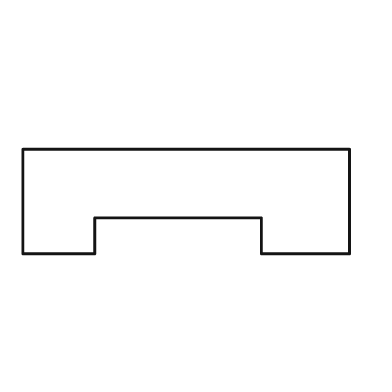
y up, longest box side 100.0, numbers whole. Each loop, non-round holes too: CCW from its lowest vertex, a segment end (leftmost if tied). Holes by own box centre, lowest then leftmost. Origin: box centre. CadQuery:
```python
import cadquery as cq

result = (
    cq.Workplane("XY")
    .moveTo(-50.0, -16.0)
    .lineTo(-28.0, -16.0)
    .lineTo(-28.0, -5.0)
    .lineTo(23.0, -5.0)
    .lineTo(23.0, -16.0)
    .lineTo(50.0, -16.0)
    .lineTo(50.0, 16.0)
    .lineTo(-50.0, 16.0)
    .close()
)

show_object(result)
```